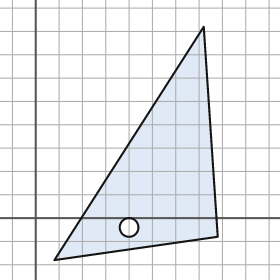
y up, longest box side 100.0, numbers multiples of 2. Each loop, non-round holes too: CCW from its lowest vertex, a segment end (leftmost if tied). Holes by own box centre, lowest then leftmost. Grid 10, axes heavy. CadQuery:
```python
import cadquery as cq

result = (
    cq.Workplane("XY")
    .moveTo(8.0, -18.0)
    .lineTo(78.0, -8.0)
    .lineTo(72.0, 82.0)
    .close()
    .moveTo(40.0, -4.0)
    .circle(4.0)
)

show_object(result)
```